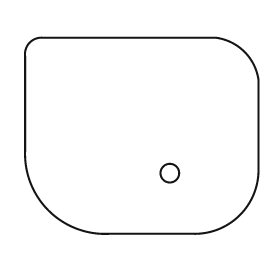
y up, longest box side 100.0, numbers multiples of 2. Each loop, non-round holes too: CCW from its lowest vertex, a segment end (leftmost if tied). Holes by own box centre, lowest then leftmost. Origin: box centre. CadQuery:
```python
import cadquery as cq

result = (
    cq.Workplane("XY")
    .moveTo(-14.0, -42.0)
    .lineTo(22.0, -42.0)
    .threePointArc((42.0, -34.0), (50.0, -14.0))
    .lineTo(50.0, 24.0)
    .threePointArc((44.0, 36.0), (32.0, 42.0))
    .lineTo(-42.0, 42.0)
    .threePointArc((-48.0, 40.0), (-50.0, 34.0))
    .lineTo(-50.0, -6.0)
    .threePointArc((-40.0, -32.0), (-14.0, -42.0))
    .close()
    .moveTo(12.0, -16.0)
    .circle(4.0)
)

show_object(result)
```